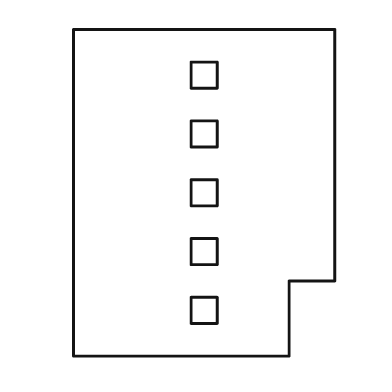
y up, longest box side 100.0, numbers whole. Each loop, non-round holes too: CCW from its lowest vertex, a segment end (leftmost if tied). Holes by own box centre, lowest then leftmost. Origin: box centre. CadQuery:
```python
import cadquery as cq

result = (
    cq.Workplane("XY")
    .moveTo(-40.0, -50.0)
    .lineTo(26.0, -50.0)
    .lineTo(26.0, -27.0)
    .lineTo(40.0, -27.0)
    .lineTo(40.0, 50.0)
    .lineTo(-40.0, 50.0)
    .close()
    .moveTo(-4.0, -40.0)
    .lineTo(4.0, -40.0)
    .lineTo(4.0, -32.0)
    .lineTo(-4.0, -32.0)
    .close()
    .moveTo(-4.0, -22.0)
    .lineTo(4.0, -22.0)
    .lineTo(4.0, -14.0)
    .lineTo(-4.0, -14.0)
    .close()
    .moveTo(-4.0, -4.0)
    .lineTo(4.0, -4.0)
    .lineTo(4.0, 4.0)
    .lineTo(-4.0, 4.0)
    .close()
    .moveTo(-4.0, 14.0)
    .lineTo(4.0, 14.0)
    .lineTo(4.0, 22.0)
    .lineTo(-4.0, 22.0)
    .close()
    .moveTo(-4.0, 32.0)
    .lineTo(4.0, 32.0)
    .lineTo(4.0, 40.0)
    .lineTo(-4.0, 40.0)
    .close()
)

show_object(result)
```